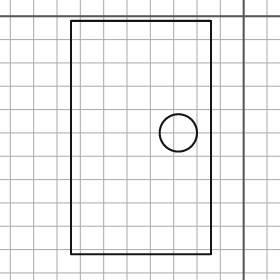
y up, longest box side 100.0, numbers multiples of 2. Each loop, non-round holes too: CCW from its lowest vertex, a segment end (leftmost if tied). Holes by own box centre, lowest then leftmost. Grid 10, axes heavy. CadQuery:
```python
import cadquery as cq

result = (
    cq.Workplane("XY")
    .moveTo(-74.0, -102.0)
    .lineTo(-14.0, -102.0)
    .lineTo(-14.0, -2.0)
    .lineTo(-74.0, -2.0)
    .close()
    .moveTo(-28.0, -50.0)
    .circle(8.0)
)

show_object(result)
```